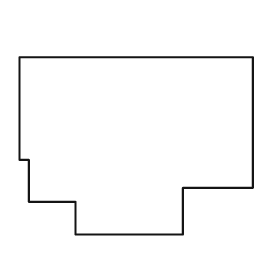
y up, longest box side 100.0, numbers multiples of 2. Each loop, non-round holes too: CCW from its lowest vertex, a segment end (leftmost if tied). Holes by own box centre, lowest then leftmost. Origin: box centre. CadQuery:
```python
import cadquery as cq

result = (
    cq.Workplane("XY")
    .moveTo(-26.0, -38.0)
    .lineTo(20.0, -38.0)
    .lineTo(20.0, -18.0)
    .lineTo(50.0, -18.0)
    .lineTo(50.0, 38.0)
    .lineTo(-50.0, 38.0)
    .lineTo(-50.0, -6.0)
    .lineTo(-46.0, -6.0)
    .lineTo(-46.0, -24.0)
    .lineTo(-26.0, -24.0)
    .close()
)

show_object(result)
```